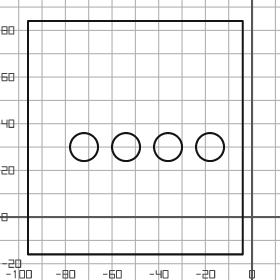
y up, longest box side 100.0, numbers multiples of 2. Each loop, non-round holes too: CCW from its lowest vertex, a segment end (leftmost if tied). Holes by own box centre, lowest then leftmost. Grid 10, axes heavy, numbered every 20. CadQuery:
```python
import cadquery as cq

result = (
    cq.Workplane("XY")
    .moveTo(-96.0, -16.0)
    .lineTo(-4.0, -16.0)
    .lineTo(-4.0, 84.0)
    .lineTo(-96.0, 84.0)
    .close()
    .moveTo(-72.0, 30.0)
    .circle(6.0)
    .moveTo(-54.0, 30.0)
    .circle(6.0)
    .moveTo(-36.0, 30.0)
    .circle(6.0)
    .moveTo(-18.0, 30.0)
    .circle(6.0)
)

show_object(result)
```